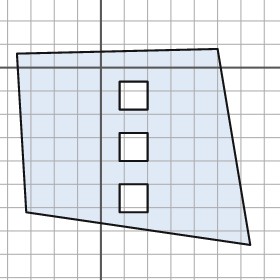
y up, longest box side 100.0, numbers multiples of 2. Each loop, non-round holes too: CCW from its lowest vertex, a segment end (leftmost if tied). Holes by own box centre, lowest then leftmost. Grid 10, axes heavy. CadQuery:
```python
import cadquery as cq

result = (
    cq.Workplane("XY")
    .moveTo(64.0, -76.0)
    .lineTo(50.0, 8.0)
    .lineTo(-36.0, 6.0)
    .lineTo(-32.0, -62.0)
    .close()
    .moveTo(8.0, -62.0)
    .lineTo(20.0, -62.0)
    .lineTo(20.0, -50.0)
    .lineTo(8.0, -50.0)
    .close()
    .moveTo(8.0, -40.0)
    .lineTo(20.0, -40.0)
    .lineTo(20.0, -28.0)
    .lineTo(8.0, -28.0)
    .close()
    .moveTo(8.0, -18.0)
    .lineTo(20.0, -18.0)
    .lineTo(20.0, -6.0)
    .lineTo(8.0, -6.0)
    .close()
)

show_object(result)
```